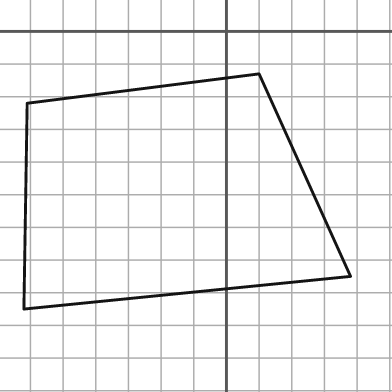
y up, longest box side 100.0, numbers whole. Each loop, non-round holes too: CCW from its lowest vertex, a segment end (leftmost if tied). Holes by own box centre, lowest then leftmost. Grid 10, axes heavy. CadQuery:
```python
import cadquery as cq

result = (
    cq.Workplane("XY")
    .moveTo(-62.0, -85.0)
    .lineTo(38.0, -75.0)
    .lineTo(10.0, -13.0)
    .lineTo(-61.0, -22.0)
    .close()
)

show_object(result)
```